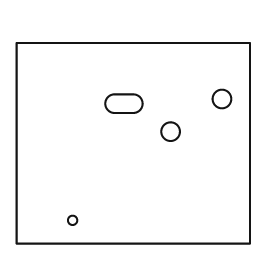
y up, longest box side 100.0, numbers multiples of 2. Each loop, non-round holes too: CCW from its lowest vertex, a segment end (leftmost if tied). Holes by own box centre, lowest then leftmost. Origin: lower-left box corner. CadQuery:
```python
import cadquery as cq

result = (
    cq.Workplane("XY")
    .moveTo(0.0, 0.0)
    .lineTo(100.0, 0.0)
    .lineTo(100.0, 86.0)
    .lineTo(0.0, 86.0)
    .close()
    .moveTo(24.0, 10.0)
    .circle(2.0)
    .moveTo(66.0, 48.0)
    .circle(4.0)
    .moveTo(42.0, 56.0)
    .lineTo(50.0, 56.0)
    .threePointArc((54.0, 60.0), (50.0, 64.0))
    .lineTo(42.0, 64.0)
    .threePointArc((38.0, 60.0), (42.0, 56.0))
    .close()
    .moveTo(88.0, 62.0)
    .circle(4.0)
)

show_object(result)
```